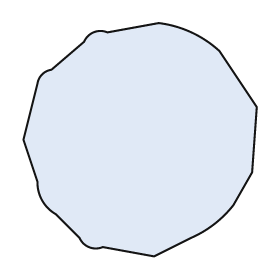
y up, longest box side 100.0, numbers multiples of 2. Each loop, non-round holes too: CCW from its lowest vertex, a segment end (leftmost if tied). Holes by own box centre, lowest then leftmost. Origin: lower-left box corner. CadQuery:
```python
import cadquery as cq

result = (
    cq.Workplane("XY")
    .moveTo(56.0, 0.0)
    .lineTo(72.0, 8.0)
    .threePointArc((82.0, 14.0), (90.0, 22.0))
    .lineTo(98.0, 36.0)
    .lineTo(100.0, 64.0)
    .lineTo(84.0, 88.0)
    .threePointArc((72.0, 96.0), (58.0, 100.0))
    .lineTo(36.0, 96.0)
    .threePointArc((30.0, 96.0), (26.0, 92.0))
    .lineTo(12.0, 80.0)
    .threePointArc((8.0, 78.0), (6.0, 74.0))
    .lineTo(0.0, 50.0)
    .lineTo(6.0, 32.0)
    .threePointArc((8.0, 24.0), (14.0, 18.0))
    .lineTo(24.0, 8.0)
    .threePointArc((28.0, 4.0), (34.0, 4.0))
    .close()
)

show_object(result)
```